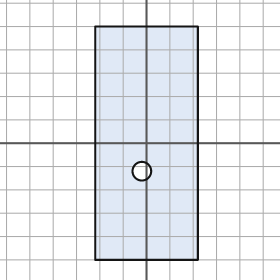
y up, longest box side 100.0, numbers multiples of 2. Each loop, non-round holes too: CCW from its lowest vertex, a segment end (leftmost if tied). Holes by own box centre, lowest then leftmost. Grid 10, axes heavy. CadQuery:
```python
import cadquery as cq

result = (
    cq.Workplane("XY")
    .moveTo(-22.0, -50.0)
    .lineTo(22.0, -50.0)
    .lineTo(22.0, 50.0)
    .lineTo(-22.0, 50.0)
    .close()
    .moveTo(-2.0, -12.0)
    .circle(4.0)
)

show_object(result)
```